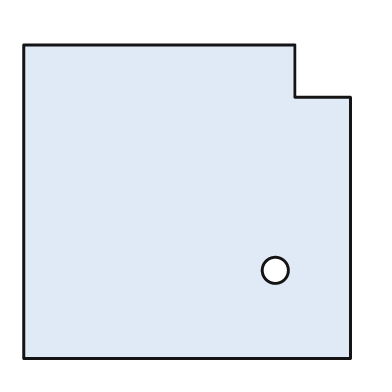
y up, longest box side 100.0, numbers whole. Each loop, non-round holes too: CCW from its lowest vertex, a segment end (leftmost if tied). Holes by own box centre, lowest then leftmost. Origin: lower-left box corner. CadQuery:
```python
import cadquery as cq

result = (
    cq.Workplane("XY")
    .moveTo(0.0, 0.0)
    .lineTo(100.0, 0.0)
    .lineTo(100.0, 80.0)
    .lineTo(83.0, 80.0)
    .lineTo(83.0, 96.0)
    .lineTo(0.0, 96.0)
    .close()
    .moveTo(77.0, 27.0)
    .circle(4.0)
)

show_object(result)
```